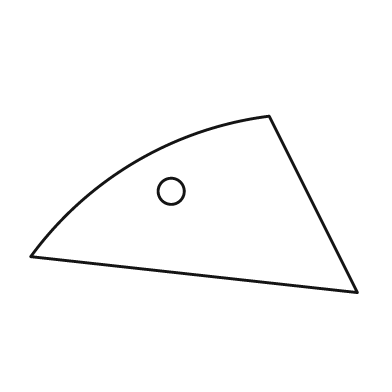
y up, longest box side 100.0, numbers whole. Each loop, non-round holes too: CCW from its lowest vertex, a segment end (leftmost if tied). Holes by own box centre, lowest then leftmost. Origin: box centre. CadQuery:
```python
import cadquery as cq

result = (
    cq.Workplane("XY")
    .moveTo(50.0, -27.0)
    .lineTo(23.0, 27.0)
    .threePointArc((-18.0, 13.0), (-50.0, -16.0))
    .close()
    .moveTo(-7.0, 4.0)
    .circle(4.0)
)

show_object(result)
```